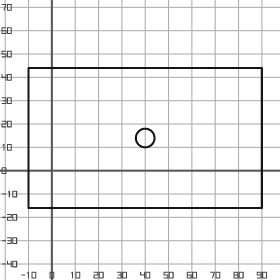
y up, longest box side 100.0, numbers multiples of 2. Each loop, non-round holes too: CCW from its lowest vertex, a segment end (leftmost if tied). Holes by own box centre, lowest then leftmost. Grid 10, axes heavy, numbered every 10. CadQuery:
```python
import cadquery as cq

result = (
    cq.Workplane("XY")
    .moveTo(-10.0, -16.0)
    .lineTo(90.0, -16.0)
    .lineTo(90.0, 44.0)
    .lineTo(-10.0, 44.0)
    .close()
    .moveTo(40.0, 14.0)
    .circle(4.0)
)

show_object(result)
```